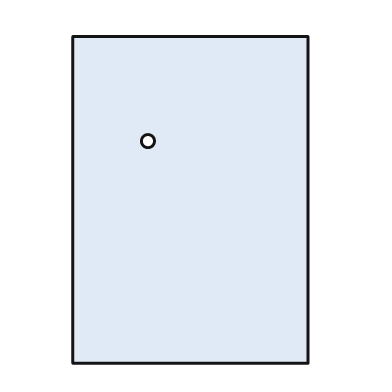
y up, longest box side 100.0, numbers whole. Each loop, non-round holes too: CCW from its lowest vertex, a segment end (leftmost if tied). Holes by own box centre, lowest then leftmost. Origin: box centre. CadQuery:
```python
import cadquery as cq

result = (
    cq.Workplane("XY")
    .moveTo(-36.0, -50.0)
    .lineTo(36.0, -50.0)
    .lineTo(36.0, 50.0)
    .lineTo(-36.0, 50.0)
    .close()
    .moveTo(-13.0, 18.0)
    .circle(2.0)
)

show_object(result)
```